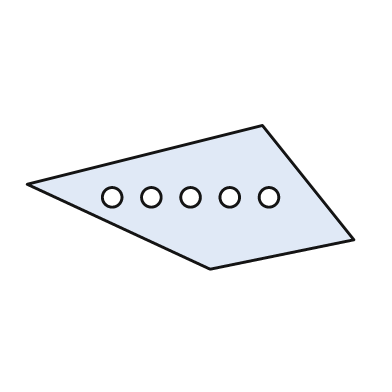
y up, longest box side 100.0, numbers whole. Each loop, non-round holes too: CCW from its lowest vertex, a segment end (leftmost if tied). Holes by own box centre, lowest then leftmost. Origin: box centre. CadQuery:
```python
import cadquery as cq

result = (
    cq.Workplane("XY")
    .moveTo(6.0, -22.0)
    .lineTo(50.0, -13.0)
    .lineTo(22.0, 22.0)
    .lineTo(-50.0, 4.0)
    .close()
    .moveTo(-24.0, 0.0)
    .circle(3.0)
    .moveTo(-12.0, 0.0)
    .circle(3.0)
    .moveTo(0.0, 0.0)
    .circle(3.0)
    .moveTo(12.0, 0.0)
    .circle(3.0)
    .moveTo(24.0, 0.0)
    .circle(3.0)
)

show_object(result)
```